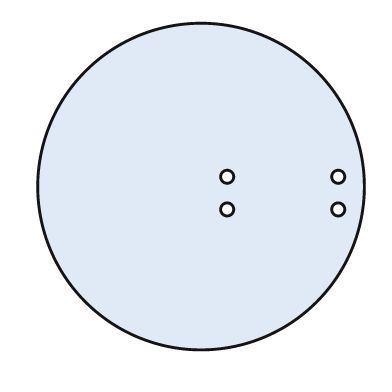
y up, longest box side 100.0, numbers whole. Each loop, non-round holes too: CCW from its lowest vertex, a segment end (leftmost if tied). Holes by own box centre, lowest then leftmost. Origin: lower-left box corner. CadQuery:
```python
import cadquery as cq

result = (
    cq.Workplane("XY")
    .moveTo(50.0, 50.0)
    .circle(50.0)
    .moveTo(58.0, 43.0)
    .circle(2.0)
    .moveTo(92.0, 43.0)
    .circle(2.0)
    .moveTo(58.0, 53.0)
    .circle(2.0)
    .moveTo(92.0, 53.0)
    .circle(2.0)
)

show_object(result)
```